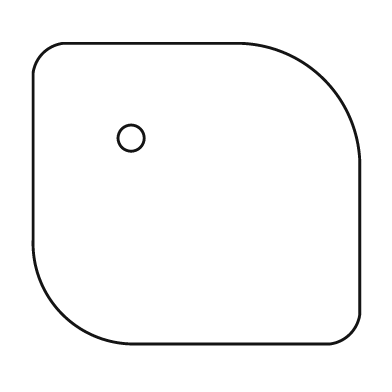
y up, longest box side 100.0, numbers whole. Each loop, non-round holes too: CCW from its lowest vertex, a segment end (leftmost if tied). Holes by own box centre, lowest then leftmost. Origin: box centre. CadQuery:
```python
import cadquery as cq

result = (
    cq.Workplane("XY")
    .moveTo(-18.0, -46.0)
    .lineTo(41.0, -46.0)
    .threePointArc((47.0, -43.0), (50.0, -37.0))
    .lineTo(50.0, 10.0)
    .threePointArc((39.0, 35.0), (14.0, 46.0))
    .lineTo(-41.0, 46.0)
    .threePointArc((-47.0, 43.0), (-50.0, 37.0))
    .lineTo(-50.0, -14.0)
    .threePointArc((-41.0, -37.0), (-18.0, -46.0))
    .close()
    .moveTo(-20.0, 17.0)
    .circle(4.0)
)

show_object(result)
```